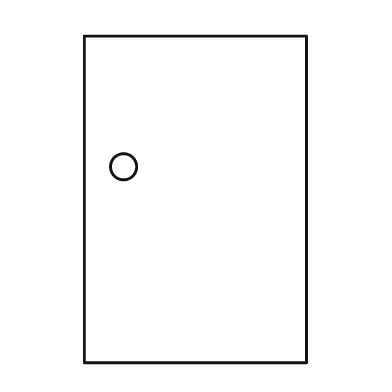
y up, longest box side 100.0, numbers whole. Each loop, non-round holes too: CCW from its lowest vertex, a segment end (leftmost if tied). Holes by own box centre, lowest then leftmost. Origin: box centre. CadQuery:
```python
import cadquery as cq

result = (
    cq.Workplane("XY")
    .moveTo(-34.0, -50.0)
    .lineTo(34.0, -50.0)
    .lineTo(34.0, 50.0)
    .lineTo(-34.0, 50.0)
    .close()
    .moveTo(-22.0, 10.0)
    .circle(4.0)
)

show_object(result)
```